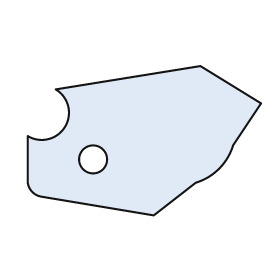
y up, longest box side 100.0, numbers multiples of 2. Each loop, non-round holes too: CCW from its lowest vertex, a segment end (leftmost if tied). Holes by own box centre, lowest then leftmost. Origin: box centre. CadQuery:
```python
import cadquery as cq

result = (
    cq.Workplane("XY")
    .moveTo(4.0, -32.0)
    .lineTo(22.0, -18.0)
    .threePointArc((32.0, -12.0), (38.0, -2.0))
    .lineTo(50.0, 16.0)
    .lineTo(24.0, 32.0)
    .lineTo(-38.0, 22.0)
    .threePointArc((-34.0, 6.0), (-50.0, 2.0))
    .lineTo(-50.0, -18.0)
    .threePointArc((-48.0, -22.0), (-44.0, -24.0))
    .close()
    .moveTo(-22.0, -8.0)
    .circle(6.0)
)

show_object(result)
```